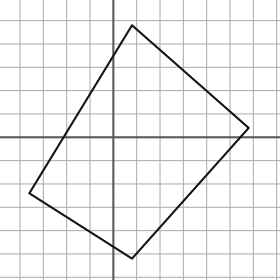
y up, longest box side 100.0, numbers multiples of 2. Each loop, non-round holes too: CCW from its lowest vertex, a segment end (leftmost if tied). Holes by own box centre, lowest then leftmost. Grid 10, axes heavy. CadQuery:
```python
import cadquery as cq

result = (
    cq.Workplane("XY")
    .moveTo(8.0, -52.0)
    .lineTo(58.0, 4.0)
    .lineTo(8.0, 48.0)
    .lineTo(-36.0, -24.0)
    .close()
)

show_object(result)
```